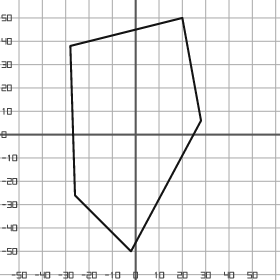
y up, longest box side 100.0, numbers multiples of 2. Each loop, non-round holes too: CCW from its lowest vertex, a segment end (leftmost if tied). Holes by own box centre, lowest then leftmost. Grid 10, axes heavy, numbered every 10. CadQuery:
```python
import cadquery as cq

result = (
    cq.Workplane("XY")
    .moveTo(-2.0, -50.0)
    .lineTo(28.0, 6.0)
    .lineTo(20.0, 50.0)
    .lineTo(-28.0, 38.0)
    .lineTo(-26.0, -26.0)
    .close()
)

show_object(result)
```